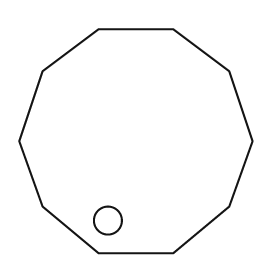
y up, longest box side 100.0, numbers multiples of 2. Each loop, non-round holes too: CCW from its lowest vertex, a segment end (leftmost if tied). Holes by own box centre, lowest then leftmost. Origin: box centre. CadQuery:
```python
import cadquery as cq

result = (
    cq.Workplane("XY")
    .moveTo(-16.0, -48.0)
    .lineTo(16.0, -48.0)
    .lineTo(40.0, -28.0)
    .lineTo(50.0, 0.0)
    .lineTo(40.0, 30.0)
    .lineTo(16.0, 48.0)
    .lineTo(-16.0, 48.0)
    .lineTo(-40.0, 30.0)
    .lineTo(-50.0, 0.0)
    .lineTo(-40.0, -28.0)
    .close()
    .moveTo(-12.0, -34.0)
    .circle(6.0)
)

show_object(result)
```